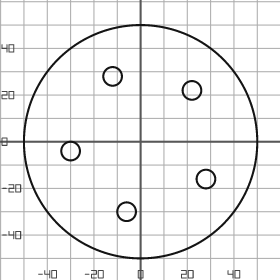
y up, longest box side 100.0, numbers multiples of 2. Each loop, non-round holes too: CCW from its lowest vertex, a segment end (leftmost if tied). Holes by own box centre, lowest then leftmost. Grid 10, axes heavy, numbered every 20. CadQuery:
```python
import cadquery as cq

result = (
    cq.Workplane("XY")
    .moveTo(0.0, 0.0)
    .circle(50.0)
    .moveTo(-6.0, -30.0)
    .circle(4.0)
    .moveTo(28.0, -16.0)
    .circle(4.0)
    .moveTo(-30.0, -4.0)
    .circle(4.0)
    .moveTo(22.0, 22.0)
    .circle(4.0)
    .moveTo(-12.0, 28.0)
    .circle(4.0)
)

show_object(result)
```